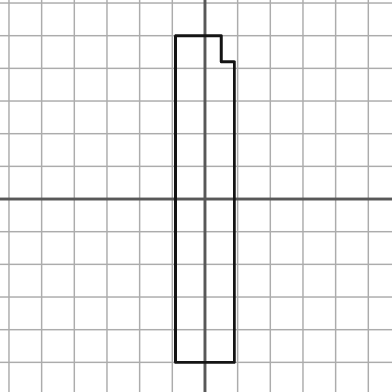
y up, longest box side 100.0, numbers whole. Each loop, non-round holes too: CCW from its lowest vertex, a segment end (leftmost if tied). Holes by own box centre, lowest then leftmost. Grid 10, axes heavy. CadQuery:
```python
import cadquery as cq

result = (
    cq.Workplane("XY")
    .moveTo(-9.0, -50.0)
    .lineTo(9.0, -50.0)
    .lineTo(9.0, 42.0)
    .lineTo(5.0, 42.0)
    .lineTo(5.0, 50.0)
    .lineTo(-9.0, 50.0)
    .close()
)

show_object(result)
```